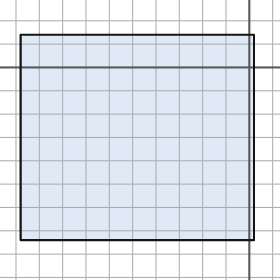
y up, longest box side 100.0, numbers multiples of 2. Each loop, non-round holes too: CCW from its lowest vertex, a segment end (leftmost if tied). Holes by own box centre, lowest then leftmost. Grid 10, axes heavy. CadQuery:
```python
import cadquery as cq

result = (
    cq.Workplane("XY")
    .moveTo(-98.0, -74.0)
    .lineTo(2.0, -74.0)
    .lineTo(2.0, 14.0)
    .lineTo(-98.0, 14.0)
    .close()
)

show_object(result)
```